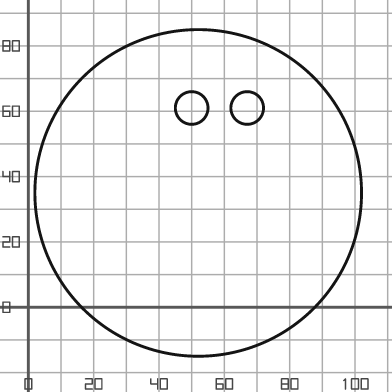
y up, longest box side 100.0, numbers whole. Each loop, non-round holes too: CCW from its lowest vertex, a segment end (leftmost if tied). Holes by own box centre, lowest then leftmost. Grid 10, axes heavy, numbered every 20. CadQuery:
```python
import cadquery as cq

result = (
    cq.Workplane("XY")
    .moveTo(52.0, 35.0)
    .circle(50.0)
    .moveTo(50.0, 61.0)
    .circle(5.0)
    .moveTo(67.0, 61.0)
    .circle(5.0)
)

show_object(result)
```